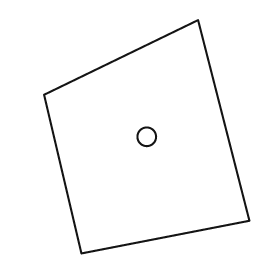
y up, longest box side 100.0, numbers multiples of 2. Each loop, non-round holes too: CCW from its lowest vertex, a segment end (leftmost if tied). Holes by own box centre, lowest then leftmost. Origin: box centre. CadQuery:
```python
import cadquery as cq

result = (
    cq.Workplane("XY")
    .moveTo(-28.0, -50.0)
    .lineTo(44.0, -36.0)
    .lineTo(22.0, 50.0)
    .lineTo(-44.0, 18.0)
    .close()
    .moveTo(0.0, 0.0)
    .circle(4.0)
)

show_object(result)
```